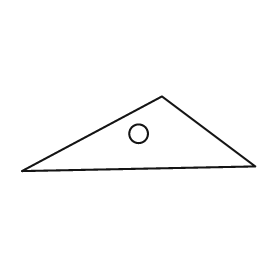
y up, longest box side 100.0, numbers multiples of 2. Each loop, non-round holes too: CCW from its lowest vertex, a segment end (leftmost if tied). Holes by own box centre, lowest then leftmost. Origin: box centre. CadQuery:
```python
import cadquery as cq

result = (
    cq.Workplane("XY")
    .moveTo(-50.0, -16.0)
    .lineTo(50.0, -14.0)
    .lineTo(10.0, 16.0)
    .close()
    .moveTo(0.0, 0.0)
    .circle(4.0)
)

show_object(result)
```